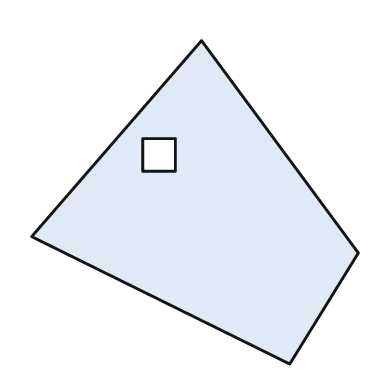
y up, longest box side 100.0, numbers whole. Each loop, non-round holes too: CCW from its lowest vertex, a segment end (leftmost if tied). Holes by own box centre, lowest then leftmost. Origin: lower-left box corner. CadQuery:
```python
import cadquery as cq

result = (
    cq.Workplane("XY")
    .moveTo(79.0, 0.0)
    .lineTo(100.0, 34.0)
    .lineTo(52.0, 99.0)
    .lineTo(0.0, 39.0)
    .close()
    .moveTo(34.0, 59.0)
    .lineTo(44.0, 59.0)
    .lineTo(44.0, 69.0)
    .lineTo(34.0, 69.0)
    .close()
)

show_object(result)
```